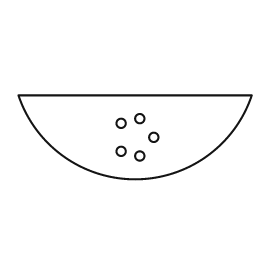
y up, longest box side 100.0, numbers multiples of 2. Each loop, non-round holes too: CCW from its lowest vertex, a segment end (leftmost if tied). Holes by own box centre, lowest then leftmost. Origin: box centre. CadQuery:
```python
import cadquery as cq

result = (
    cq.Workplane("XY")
    .moveTo(-50.0, 18.0)
    .threePointArc((0.0, -18.0), (50.0, 18.0))
    .close()
    .moveTo(2.0, -8.0)
    .circle(2.0)
    .moveTo(-6.0, -6.0)
    .circle(2.0)
    .moveTo(8.0, 0.0)
    .circle(2.0)
    .moveTo(-6.0, 6.0)
    .circle(2.0)
    .moveTo(2.0, 8.0)
    .circle(2.0)
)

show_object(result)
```